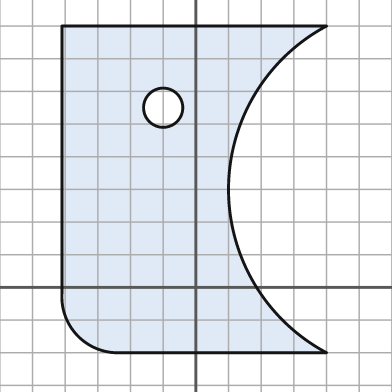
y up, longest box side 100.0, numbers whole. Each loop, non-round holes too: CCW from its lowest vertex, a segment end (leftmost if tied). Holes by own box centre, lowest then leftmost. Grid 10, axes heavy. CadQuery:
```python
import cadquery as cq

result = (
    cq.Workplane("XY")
    .moveTo(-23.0, -20.0)
    .lineTo(40.0, -20.0)
    .threePointArc((10.0, 30.0), (40.0, 80.0))
    .lineTo(-41.0, 80.0)
    .lineTo(-41.0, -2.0)
    .threePointArc((-36.0, -15.0), (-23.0, -20.0))
    .close()
    .moveTo(-10.0, 55.0)
    .circle(6.0)
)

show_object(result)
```